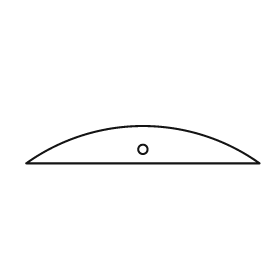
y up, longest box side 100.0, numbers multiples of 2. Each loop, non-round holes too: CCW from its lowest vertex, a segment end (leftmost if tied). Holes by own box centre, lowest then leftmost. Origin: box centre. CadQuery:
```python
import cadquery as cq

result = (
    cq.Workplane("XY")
    .moveTo(-50.0, -8.0)
    .lineTo(50.0, -8.0)
    .threePointArc((0.0, 8.0), (-50.0, -8.0))
    .close()
    .moveTo(0.0, -2.0)
    .circle(2.0)
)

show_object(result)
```